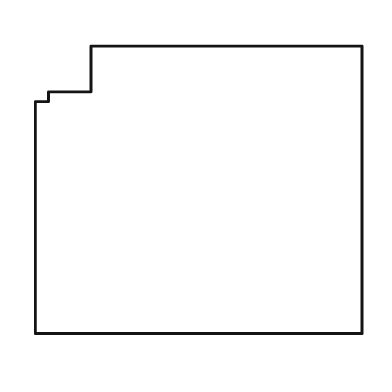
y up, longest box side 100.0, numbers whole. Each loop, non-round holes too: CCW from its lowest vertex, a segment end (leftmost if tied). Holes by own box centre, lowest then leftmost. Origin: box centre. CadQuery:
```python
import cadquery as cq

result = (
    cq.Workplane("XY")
    .moveTo(-50.0, -44.0)
    .lineTo(50.0, -44.0)
    .lineTo(50.0, 44.0)
    .lineTo(-33.0, 44.0)
    .lineTo(-33.0, 30.0)
    .lineTo(-46.0, 30.0)
    .lineTo(-46.0, 27.0)
    .lineTo(-50.0, 27.0)
    .close()
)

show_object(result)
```